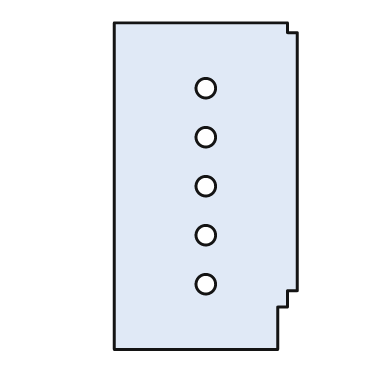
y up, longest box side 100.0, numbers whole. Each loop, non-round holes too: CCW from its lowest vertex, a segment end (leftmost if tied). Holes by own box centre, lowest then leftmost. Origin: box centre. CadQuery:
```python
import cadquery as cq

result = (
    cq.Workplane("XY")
    .moveTo(-28.0, -50.0)
    .lineTo(22.0, -50.0)
    .lineTo(22.0, -37.0)
    .lineTo(25.0, -37.0)
    .lineTo(25.0, -32.0)
    .lineTo(28.0, -32.0)
    .lineTo(28.0, 47.0)
    .lineTo(25.0, 47.0)
    .lineTo(25.0, 50.0)
    .lineTo(-28.0, 50.0)
    .close()
    .moveTo(0.0, -30.0)
    .circle(3.0)
    .moveTo(0.0, -15.0)
    .circle(3.0)
    .moveTo(0.0, 0.0)
    .circle(3.0)
    .moveTo(0.0, 15.0)
    .circle(3.0)
    .moveTo(0.0, 30.0)
    .circle(3.0)
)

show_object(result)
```